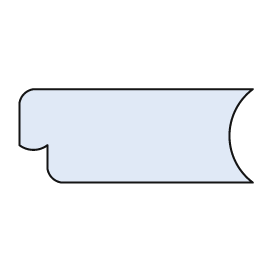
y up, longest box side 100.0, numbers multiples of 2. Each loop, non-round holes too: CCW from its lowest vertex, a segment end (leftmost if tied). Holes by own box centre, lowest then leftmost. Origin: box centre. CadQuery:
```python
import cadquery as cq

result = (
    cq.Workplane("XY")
    .moveTo(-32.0, -20.0)
    .lineTo(50.0, -20.0)
    .threePointArc((40.0, 0.0), (50.0, 20.0))
    .lineTo(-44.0, 20.0)
    .threePointArc((-48.0, 18.0), (-50.0, 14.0))
    .lineTo(-50.0, -4.0)
    .threePointArc((-44.0, -6.0), (-38.0, -4.0))
    .lineTo(-38.0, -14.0)
    .threePointArc((-36.0, -18.0), (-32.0, -20.0))
    .close()
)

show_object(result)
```